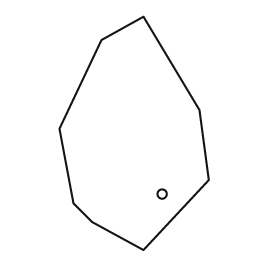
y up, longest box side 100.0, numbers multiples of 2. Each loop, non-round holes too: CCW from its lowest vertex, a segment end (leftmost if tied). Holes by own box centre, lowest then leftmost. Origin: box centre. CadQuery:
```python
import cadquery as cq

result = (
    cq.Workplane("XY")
    .moveTo(4.0, -50.0)
    .lineTo(32.0, -20.0)
    .lineTo(28.0, 10.0)
    .lineTo(4.0, 50.0)
    .lineTo(-14.0, 40.0)
    .lineTo(-32.0, 2.0)
    .lineTo(-26.0, -30.0)
    .lineTo(-18.0, -38.0)
    .close()
    .moveTo(12.0, -26.0)
    .circle(2.0)
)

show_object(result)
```